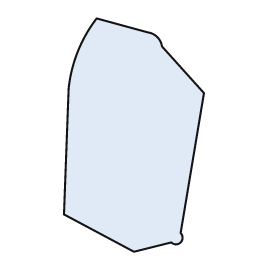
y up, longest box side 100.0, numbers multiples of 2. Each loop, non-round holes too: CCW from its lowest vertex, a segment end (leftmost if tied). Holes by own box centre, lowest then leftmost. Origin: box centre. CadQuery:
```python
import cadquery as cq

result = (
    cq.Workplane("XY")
    .moveTo(0.0, -50.0)
    .lineTo(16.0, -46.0)
    .threePointArc((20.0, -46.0), (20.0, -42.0))
    .lineTo(30.0, 18.0)
    .lineTo(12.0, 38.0)
    .threePointArc((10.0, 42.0), (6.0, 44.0))
    .lineTo(-16.0, 50.0)
    .threePointArc((-24.0, 36.0), (-28.0, 20.0))
    .lineTo(-30.0, -34.0)
    .close()
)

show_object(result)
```